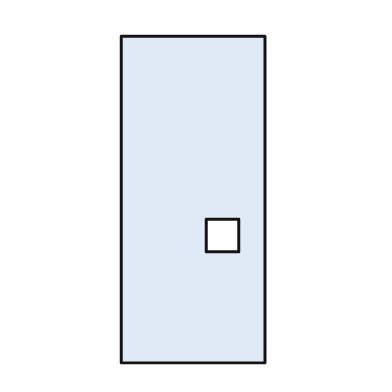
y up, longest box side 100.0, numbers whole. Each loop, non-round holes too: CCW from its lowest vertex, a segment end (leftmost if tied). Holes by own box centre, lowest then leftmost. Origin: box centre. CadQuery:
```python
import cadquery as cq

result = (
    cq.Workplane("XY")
    .moveTo(-22.0, -50.0)
    .lineTo(22.0, -50.0)
    .lineTo(22.0, 50.0)
    .lineTo(-22.0, 50.0)
    .close()
    .moveTo(4.0, -16.0)
    .lineTo(14.0, -16.0)
    .lineTo(14.0, -6.0)
    .lineTo(4.0, -6.0)
    .close()
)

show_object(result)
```